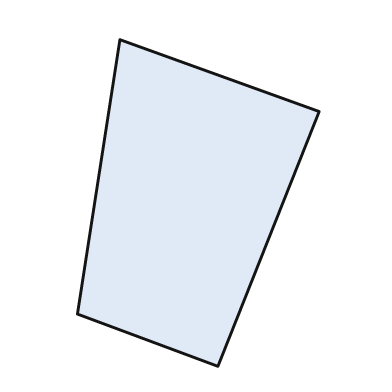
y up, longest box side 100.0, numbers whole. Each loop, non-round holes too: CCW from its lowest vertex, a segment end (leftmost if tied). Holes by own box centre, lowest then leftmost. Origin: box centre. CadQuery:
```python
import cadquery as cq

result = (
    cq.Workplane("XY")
    .moveTo(6.0, -50.0)
    .lineTo(37.0, 28.0)
    .lineTo(-24.0, 50.0)
    .lineTo(-37.0, -34.0)
    .close()
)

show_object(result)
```